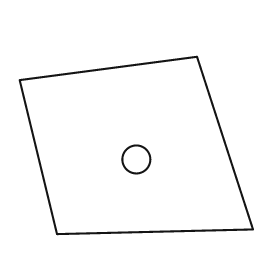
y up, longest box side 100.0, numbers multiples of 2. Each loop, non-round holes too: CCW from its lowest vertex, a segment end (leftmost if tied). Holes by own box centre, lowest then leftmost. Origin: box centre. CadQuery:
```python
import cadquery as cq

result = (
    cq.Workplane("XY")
    .moveTo(-34.0, -38.0)
    .lineTo(50.0, -36.0)
    .lineTo(26.0, 38.0)
    .lineTo(-50.0, 28.0)
    .close()
    .moveTo(0.0, -6.0)
    .circle(6.0)
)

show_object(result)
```